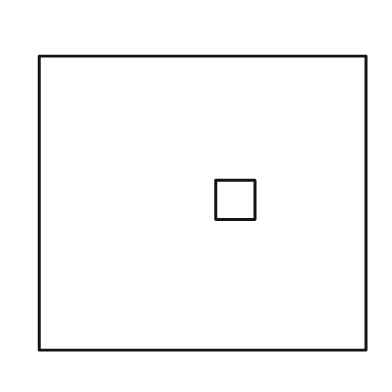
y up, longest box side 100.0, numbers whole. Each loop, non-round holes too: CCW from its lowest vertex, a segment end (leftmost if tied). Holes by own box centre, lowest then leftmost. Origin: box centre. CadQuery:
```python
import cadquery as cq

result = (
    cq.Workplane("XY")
    .moveTo(-50.0, -45.0)
    .lineTo(50.0, -45.0)
    .lineTo(50.0, 45.0)
    .lineTo(-50.0, 45.0)
    .close()
    .moveTo(4.0, -5.0)
    .lineTo(16.0, -5.0)
    .lineTo(16.0, 7.0)
    .lineTo(4.0, 7.0)
    .close()
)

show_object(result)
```